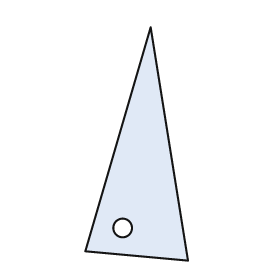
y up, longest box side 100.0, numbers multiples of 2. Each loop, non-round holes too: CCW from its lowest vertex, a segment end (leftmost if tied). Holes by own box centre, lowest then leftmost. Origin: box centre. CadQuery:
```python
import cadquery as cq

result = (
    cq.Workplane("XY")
    .moveTo(22.0, -50.0)
    .lineTo(6.0, 50.0)
    .lineTo(-22.0, -46.0)
    .close()
    .moveTo(-6.0, -36.0)
    .circle(4.0)
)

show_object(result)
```